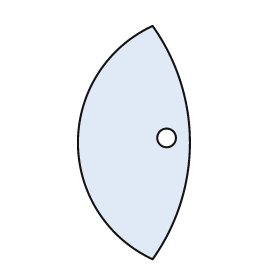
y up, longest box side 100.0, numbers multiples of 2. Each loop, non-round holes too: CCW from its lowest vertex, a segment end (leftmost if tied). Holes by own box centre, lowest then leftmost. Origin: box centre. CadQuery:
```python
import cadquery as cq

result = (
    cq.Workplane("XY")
    .moveTo(8.0, -50.0)
    .threePointArc((24.0, 0.0), (8.0, 50.0))
    .threePointArc((-24.0, 0.0), (8.0, -50.0))
    .close()
    .moveTo(14.0, 2.0)
    .circle(4.0)
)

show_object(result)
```